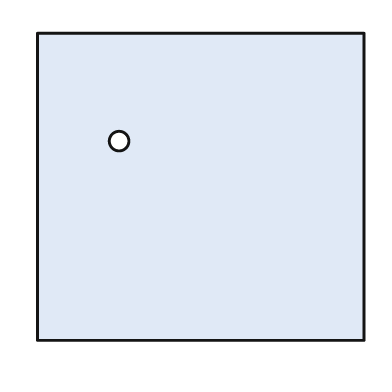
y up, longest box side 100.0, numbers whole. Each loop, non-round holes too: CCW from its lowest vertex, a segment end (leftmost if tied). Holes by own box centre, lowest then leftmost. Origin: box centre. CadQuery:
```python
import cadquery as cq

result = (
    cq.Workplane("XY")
    .moveTo(-50.0, -47.0)
    .lineTo(50.0, -47.0)
    .lineTo(50.0, 47.0)
    .lineTo(-50.0, 47.0)
    .close()
    .moveTo(-25.0, 14.0)
    .circle(3.0)
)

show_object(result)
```